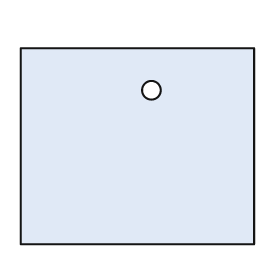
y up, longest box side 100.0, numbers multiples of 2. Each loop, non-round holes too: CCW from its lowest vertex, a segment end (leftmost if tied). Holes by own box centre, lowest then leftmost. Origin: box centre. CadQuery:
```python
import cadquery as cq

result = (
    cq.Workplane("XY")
    .moveTo(-50.0, -42.0)
    .lineTo(50.0, -42.0)
    .lineTo(50.0, 42.0)
    .lineTo(-50.0, 42.0)
    .close()
    .moveTo(6.0, 24.0)
    .circle(4.0)
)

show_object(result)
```